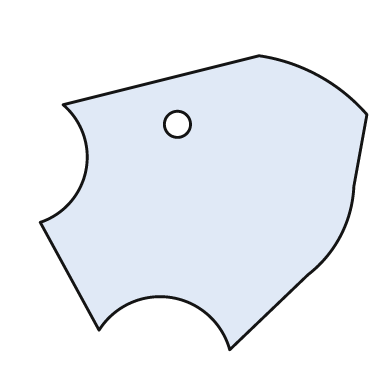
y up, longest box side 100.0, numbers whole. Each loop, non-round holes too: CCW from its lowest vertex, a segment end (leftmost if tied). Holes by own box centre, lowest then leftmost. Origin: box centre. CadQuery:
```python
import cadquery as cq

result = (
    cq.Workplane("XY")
    .moveTo(8.0, -45.0)
    .lineTo(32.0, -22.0)
    .threePointArc((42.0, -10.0), (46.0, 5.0))
    .lineTo(50.0, 27.0)
    .threePointArc((35.0, 39.0), (17.0, 45.0))
    .lineTo(-43.0, 30.0)
    .threePointArc((-36.0, 10.0), (-50.0, -6.0))
    .lineTo(-32.0, -39.0)
    .threePointArc((-10.0, -29.0), (8.0, -45.0))
    .close()
    .moveTo(-8.0, 24.0)
    .circle(4.0)
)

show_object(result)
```